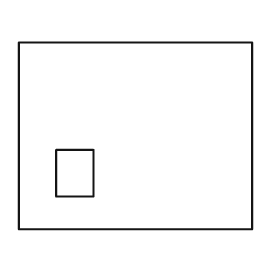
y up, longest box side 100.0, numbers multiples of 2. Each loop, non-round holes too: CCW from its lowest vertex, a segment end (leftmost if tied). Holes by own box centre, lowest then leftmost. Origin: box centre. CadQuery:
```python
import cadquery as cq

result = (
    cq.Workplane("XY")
    .moveTo(-50.0, -40.0)
    .lineTo(50.0, -40.0)
    .lineTo(50.0, 40.0)
    .lineTo(-50.0, 40.0)
    .close()
    .moveTo(-34.0, -26.0)
    .lineTo(-18.0, -26.0)
    .lineTo(-18.0, -6.0)
    .lineTo(-34.0, -6.0)
    .close()
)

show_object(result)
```